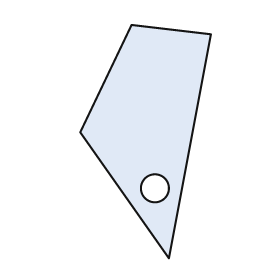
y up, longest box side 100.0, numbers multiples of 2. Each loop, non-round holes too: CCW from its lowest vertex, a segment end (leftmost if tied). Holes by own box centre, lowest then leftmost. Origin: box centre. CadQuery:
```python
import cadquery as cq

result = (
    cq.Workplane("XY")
    .moveTo(10.0, -50.0)
    .lineTo(28.0, 46.0)
    .lineTo(-6.0, 50.0)
    .lineTo(-28.0, 4.0)
    .close()
    .moveTo(4.0, -20.0)
    .circle(6.0)
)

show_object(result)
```